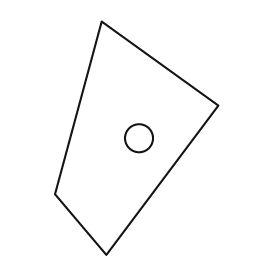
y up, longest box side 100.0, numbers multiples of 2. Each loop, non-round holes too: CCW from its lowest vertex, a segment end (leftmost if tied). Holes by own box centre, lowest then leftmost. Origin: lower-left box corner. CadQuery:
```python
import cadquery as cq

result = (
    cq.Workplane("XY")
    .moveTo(22.0, 0.0)
    .lineTo(70.0, 64.0)
    .lineTo(20.0, 100.0)
    .lineTo(0.0, 26.0)
    .close()
    .moveTo(36.0, 50.0)
    .circle(6.0)
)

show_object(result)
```